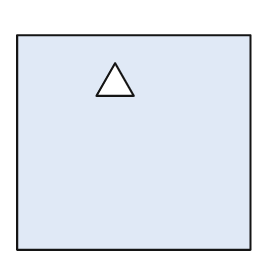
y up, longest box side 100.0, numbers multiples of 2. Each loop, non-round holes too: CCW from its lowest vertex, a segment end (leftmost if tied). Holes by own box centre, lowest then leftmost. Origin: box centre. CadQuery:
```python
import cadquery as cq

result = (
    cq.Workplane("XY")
    .moveTo(-50.0, -46.0)
    .lineTo(50.0, -46.0)
    .lineTo(50.0, 46.0)
    .lineTo(-50.0, 46.0)
    .close()
    .moveTo(-16.0, 20.0)
    .lineTo(0.0, 20.0)
    .lineTo(-8.0, 34.0)
    .close()
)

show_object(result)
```